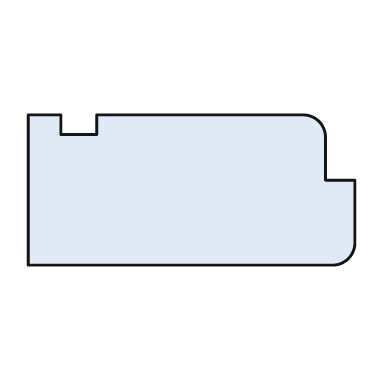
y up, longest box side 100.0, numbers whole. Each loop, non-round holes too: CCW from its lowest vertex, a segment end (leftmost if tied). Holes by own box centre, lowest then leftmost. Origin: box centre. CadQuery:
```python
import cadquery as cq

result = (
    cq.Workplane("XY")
    .moveTo(-50.0, -23.0)
    .lineTo(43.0, -23.0)
    .threePointArc((48.0, -21.0), (50.0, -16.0))
    .lineTo(50.0, 3.0)
    .lineTo(41.0, 3.0)
    .lineTo(41.0, 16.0)
    .threePointArc((39.0, 21.0), (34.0, 23.0))
    .lineTo(-29.0, 23.0)
    .lineTo(-29.0, 17.0)
    .lineTo(-40.0, 17.0)
    .lineTo(-40.0, 23.0)
    .lineTo(-50.0, 23.0)
    .close()
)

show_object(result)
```